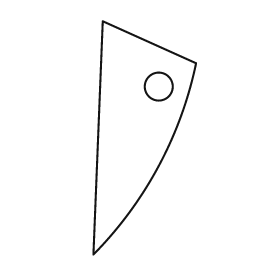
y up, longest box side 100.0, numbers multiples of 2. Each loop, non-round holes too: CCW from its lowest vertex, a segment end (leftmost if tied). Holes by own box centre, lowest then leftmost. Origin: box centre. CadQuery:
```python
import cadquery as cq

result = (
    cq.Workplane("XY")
    .moveTo(-22.0, -50.0)
    .threePointArc((6.0, -12.0), (22.0, 32.0))
    .lineTo(-18.0, 50.0)
    .close()
    .moveTo(6.0, 22.0)
    .circle(6.0)
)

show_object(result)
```